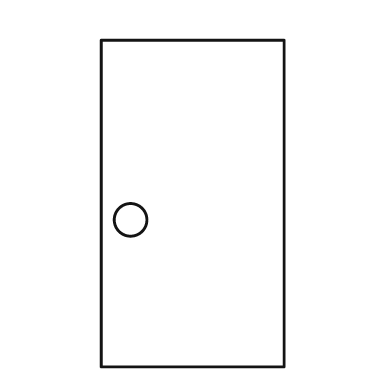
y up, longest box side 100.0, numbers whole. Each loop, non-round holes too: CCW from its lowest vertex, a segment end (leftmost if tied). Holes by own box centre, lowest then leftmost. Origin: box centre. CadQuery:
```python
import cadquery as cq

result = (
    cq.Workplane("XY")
    .moveTo(-28.0, -50.0)
    .lineTo(28.0, -50.0)
    .lineTo(28.0, 50.0)
    .lineTo(-28.0, 50.0)
    .close()
    .moveTo(-19.0, -5.0)
    .circle(5.0)
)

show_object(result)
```